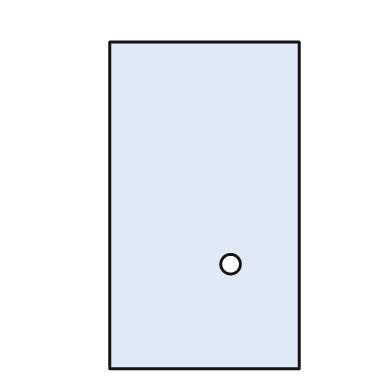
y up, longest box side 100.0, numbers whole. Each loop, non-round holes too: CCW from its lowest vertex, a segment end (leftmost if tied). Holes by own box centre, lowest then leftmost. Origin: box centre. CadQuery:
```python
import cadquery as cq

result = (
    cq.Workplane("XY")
    .moveTo(-29.0, -50.0)
    .lineTo(29.0, -50.0)
    .lineTo(29.0, 50.0)
    .lineTo(-29.0, 50.0)
    .close()
    .moveTo(8.0, -18.0)
    .circle(3.0)
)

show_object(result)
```